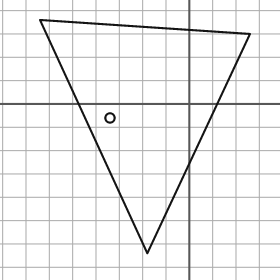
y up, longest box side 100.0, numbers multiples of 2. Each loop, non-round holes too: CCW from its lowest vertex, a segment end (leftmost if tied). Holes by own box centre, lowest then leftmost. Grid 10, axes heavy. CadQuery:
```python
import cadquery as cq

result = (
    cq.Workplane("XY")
    .moveTo(-18.0, -64.0)
    .lineTo(26.0, 30.0)
    .lineTo(-64.0, 36.0)
    .close()
    .moveTo(-34.0, -6.0)
    .circle(2.0)
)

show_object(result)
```